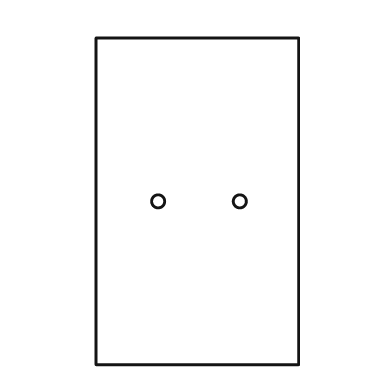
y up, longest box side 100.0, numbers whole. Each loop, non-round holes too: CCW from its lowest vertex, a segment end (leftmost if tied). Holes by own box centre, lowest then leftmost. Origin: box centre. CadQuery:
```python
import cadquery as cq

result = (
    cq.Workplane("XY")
    .moveTo(-31.0, -50.0)
    .lineTo(31.0, -50.0)
    .lineTo(31.0, 50.0)
    .lineTo(-31.0, 50.0)
    .close()
    .moveTo(-12.0, 0.0)
    .circle(2.0)
    .moveTo(13.0, 0.0)
    .circle(2.0)
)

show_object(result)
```